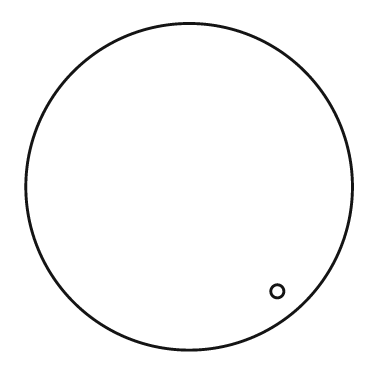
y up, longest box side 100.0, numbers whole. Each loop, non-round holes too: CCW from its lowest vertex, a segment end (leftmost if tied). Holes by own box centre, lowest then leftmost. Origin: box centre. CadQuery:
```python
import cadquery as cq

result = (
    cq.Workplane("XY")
    .moveTo(0.0, 0.0)
    .circle(50.0)
    .moveTo(27.0, -32.0)
    .circle(2.0)
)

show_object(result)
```